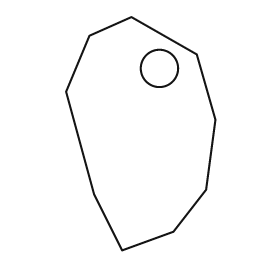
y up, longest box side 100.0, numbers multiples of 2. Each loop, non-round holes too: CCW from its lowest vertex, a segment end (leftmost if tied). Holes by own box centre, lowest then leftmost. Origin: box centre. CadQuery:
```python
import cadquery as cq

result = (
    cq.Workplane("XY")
    .moveTo(-8.0, -50.0)
    .lineTo(14.0, -42.0)
    .lineTo(28.0, -24.0)
    .lineTo(32.0, 6.0)
    .lineTo(24.0, 34.0)
    .lineTo(-4.0, 50.0)
    .lineTo(-22.0, 42.0)
    .lineTo(-32.0, 18.0)
    .lineTo(-20.0, -26.0)
    .close()
    .moveTo(8.0, 28.0)
    .circle(8.0)
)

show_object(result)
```